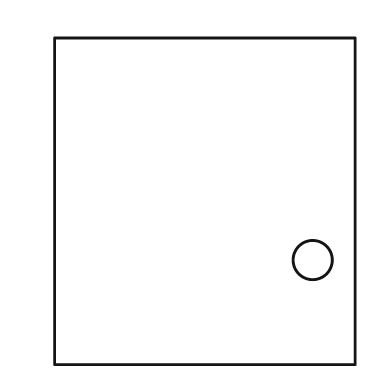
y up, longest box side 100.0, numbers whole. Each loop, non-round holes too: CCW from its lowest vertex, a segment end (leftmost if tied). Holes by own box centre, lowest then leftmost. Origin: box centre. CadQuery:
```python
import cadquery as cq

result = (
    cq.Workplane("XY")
    .moveTo(-46.0, -50.0)
    .lineTo(46.0, -50.0)
    .lineTo(46.0, 50.0)
    .lineTo(-46.0, 50.0)
    .close()
    .moveTo(33.0, -18.0)
    .circle(6.0)
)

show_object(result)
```